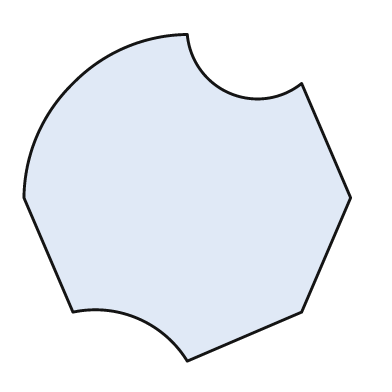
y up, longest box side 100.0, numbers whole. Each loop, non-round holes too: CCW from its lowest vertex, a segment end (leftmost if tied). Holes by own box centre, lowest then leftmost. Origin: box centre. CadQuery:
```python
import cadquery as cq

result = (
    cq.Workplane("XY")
    .moveTo(0.0, -50.0)
    .lineTo(35.0, -35.0)
    .lineTo(50.0, 0.0)
    .lineTo(35.0, 35.0)
    .threePointArc((13.0, 32.0), (0.0, 50.0))
    .threePointArc((-19.0, 46.0), (-35.0, 35.0))
    .threePointArc((-46.0, 19.0), (-50.0, 0.0))
    .lineTo(-35.0, -35.0)
    .threePointArc((-15.0, -37.0), (0.0, -50.0))
    .close()
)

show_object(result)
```